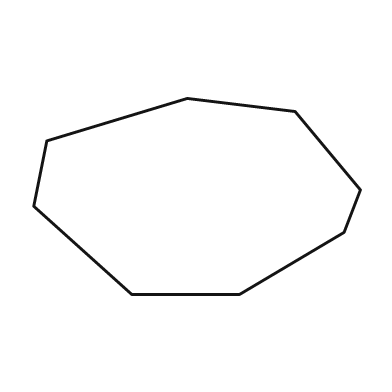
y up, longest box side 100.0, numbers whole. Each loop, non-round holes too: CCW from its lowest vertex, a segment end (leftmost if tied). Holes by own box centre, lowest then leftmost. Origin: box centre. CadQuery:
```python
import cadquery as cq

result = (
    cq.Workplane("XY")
    .moveTo(-20.0, -30.0)
    .lineTo(13.0, -30.0)
    .lineTo(45.0, -11.0)
    .lineTo(50.0, 2.0)
    .lineTo(30.0, 26.0)
    .lineTo(-3.0, 30.0)
    .lineTo(-46.0, 17.0)
    .lineTo(-50.0, -3.0)
    .close()
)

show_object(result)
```